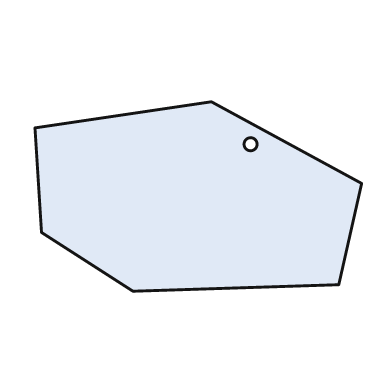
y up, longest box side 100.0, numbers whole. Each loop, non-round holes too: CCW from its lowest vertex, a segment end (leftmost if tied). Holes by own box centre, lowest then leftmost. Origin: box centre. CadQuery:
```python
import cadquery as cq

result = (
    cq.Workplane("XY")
    .moveTo(-20.0, -29.0)
    .lineTo(43.0, -27.0)
    .lineTo(50.0, 4.0)
    .lineTo(4.0, 29.0)
    .lineTo(-50.0, 21.0)
    .lineTo(-48.0, -11.0)
    .close()
    .moveTo(16.0, 16.0)
    .circle(2.0)
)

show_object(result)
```